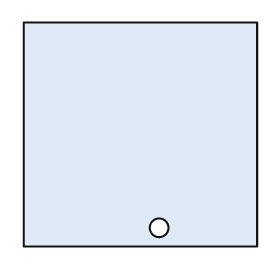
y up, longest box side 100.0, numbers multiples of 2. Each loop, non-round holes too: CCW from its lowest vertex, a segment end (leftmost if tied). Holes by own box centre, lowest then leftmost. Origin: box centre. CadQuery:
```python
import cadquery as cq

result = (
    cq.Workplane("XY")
    .moveTo(-50.0, -48.0)
    .lineTo(50.0, -48.0)
    .lineTo(50.0, 48.0)
    .lineTo(-50.0, 48.0)
    .close()
    .moveTo(8.0, -40.0)
    .circle(4.0)
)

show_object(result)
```